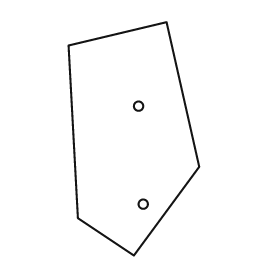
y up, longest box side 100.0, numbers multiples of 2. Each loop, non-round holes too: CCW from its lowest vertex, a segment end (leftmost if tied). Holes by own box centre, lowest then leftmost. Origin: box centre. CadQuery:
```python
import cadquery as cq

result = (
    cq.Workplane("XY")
    .moveTo(0.0, -50.0)
    .lineTo(28.0, -12.0)
    .lineTo(14.0, 50.0)
    .lineTo(-28.0, 40.0)
    .lineTo(-24.0, -34.0)
    .close()
    .moveTo(4.0, -28.0)
    .circle(2.0)
    .moveTo(2.0, 14.0)
    .circle(2.0)
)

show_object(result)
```